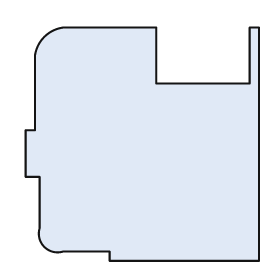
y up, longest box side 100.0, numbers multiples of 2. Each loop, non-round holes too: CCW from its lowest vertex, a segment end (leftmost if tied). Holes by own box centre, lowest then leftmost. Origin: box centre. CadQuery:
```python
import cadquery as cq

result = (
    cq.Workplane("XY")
    .moveTo(-14.0, -50.0)
    .lineTo(50.0, -50.0)
    .lineTo(50.0, 50.0)
    .lineTo(46.0, 50.0)
    .lineTo(46.0, 26.0)
    .lineTo(6.0, 26.0)
    .lineTo(6.0, 50.0)
    .lineTo(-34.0, 50.0)
    .threePointArc((-42.0, 46.0), (-46.0, 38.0))
    .lineTo(-46.0, 6.0)
    .lineTo(-50.0, 6.0)
    .lineTo(-50.0, -14.0)
    .lineTo(-44.0, -14.0)
    .lineTo(-44.0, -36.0)
    .threePointArc((-42.0, -44.0), (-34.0, -46.0))
    .lineTo(-14.0, -46.0)
    .close()
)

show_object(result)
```